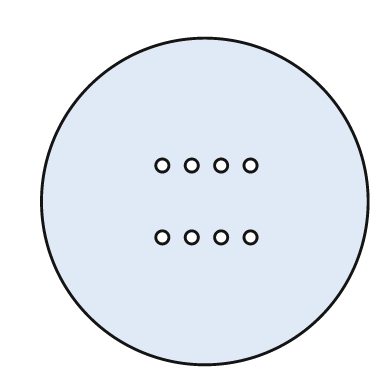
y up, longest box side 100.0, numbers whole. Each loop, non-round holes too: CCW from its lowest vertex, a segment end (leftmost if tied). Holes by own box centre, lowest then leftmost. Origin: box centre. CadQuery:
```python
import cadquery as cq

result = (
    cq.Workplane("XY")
    .moveTo(0.0, 0.0)
    .circle(50.0)
    .moveTo(-13.0, -11.0)
    .circle(2.0)
    .moveTo(-4.0, -11.0)
    .circle(2.0)
    .moveTo(5.0, -11.0)
    .circle(2.0)
    .moveTo(14.0, -11.0)
    .circle(2.0)
    .moveTo(-13.0, 11.0)
    .circle(2.0)
    .moveTo(-4.0, 11.0)
    .circle(2.0)
    .moveTo(5.0, 11.0)
    .circle(2.0)
    .moveTo(14.0, 11.0)
    .circle(2.0)
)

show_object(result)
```